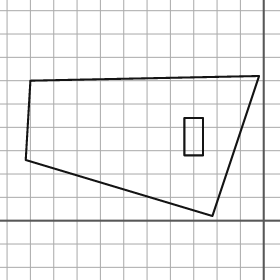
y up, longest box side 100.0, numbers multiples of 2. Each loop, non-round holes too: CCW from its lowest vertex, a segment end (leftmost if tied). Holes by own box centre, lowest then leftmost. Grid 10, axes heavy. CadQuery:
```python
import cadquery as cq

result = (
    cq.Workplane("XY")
    .moveTo(-22.0, 2.0)
    .lineTo(-2.0, 62.0)
    .lineTo(-100.0, 60.0)
    .lineTo(-102.0, 26.0)
    .close()
    .moveTo(-34.0, 28.0)
    .lineTo(-26.0, 28.0)
    .lineTo(-26.0, 44.0)
    .lineTo(-34.0, 44.0)
    .close()
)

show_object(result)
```